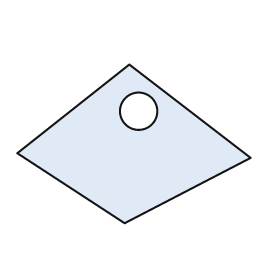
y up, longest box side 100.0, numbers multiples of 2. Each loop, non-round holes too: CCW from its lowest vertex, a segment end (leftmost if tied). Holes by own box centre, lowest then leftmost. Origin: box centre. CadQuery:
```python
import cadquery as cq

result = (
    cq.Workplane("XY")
    .moveTo(-4.0, -34.0)
    .lineTo(50.0, -6.0)
    .lineTo(-2.0, 34.0)
    .lineTo(-50.0, -4.0)
    .close()
    .moveTo(2.0, 14.0)
    .circle(8.0)
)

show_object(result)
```